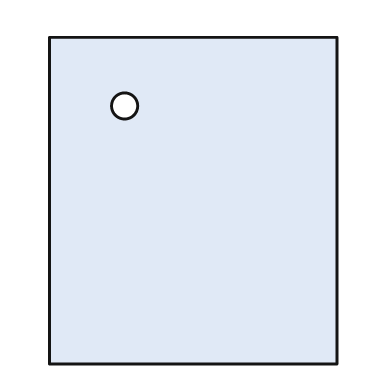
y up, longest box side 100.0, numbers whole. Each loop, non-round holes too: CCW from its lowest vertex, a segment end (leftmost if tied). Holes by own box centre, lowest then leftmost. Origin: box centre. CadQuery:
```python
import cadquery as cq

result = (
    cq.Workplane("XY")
    .moveTo(-44.0, -50.0)
    .lineTo(44.0, -50.0)
    .lineTo(44.0, 50.0)
    .lineTo(-44.0, 50.0)
    .close()
    .moveTo(-21.0, 29.0)
    .circle(4.0)
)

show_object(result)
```